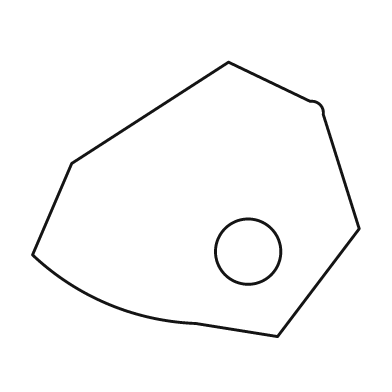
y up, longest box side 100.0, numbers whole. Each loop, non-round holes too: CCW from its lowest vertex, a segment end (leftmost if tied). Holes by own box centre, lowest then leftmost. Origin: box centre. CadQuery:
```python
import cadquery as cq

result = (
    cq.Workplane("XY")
    .moveTo(25.0, -42.0)
    .lineTo(50.0, -9.0)
    .lineTo(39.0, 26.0)
    .threePointArc((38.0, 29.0), (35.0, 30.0))
    .lineTo(10.0, 42.0)
    .lineTo(-38.0, 11.0)
    .lineTo(-50.0, -17.0)
    .threePointArc((-27.0, -32.0), (0.0, -38.0))
    .close()
    .moveTo(16.0, -16.0)
    .circle(10.0)
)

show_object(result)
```